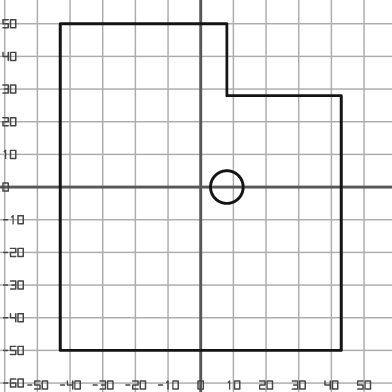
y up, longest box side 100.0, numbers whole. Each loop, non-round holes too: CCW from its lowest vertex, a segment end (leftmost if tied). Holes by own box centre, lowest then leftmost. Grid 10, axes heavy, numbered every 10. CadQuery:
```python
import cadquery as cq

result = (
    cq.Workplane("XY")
    .moveTo(-43.0, -50.0)
    .lineTo(43.0, -50.0)
    .lineTo(43.0, 28.0)
    .lineTo(8.0, 28.0)
    .lineTo(8.0, 50.0)
    .lineTo(-43.0, 50.0)
    .close()
    .moveTo(8.0, 0.0)
    .circle(5.0)
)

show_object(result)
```